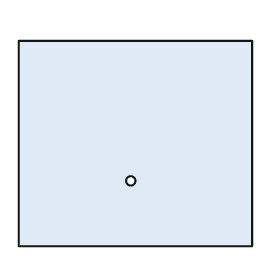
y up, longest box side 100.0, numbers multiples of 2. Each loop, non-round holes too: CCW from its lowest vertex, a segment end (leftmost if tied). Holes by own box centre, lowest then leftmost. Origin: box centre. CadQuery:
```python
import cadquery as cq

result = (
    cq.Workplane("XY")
    .moveTo(-50.0, -44.0)
    .lineTo(50.0, -44.0)
    .lineTo(50.0, 44.0)
    .lineTo(-50.0, 44.0)
    .close()
    .moveTo(-2.0, -16.0)
    .circle(2.0)
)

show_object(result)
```